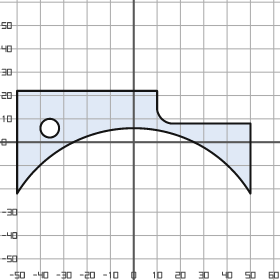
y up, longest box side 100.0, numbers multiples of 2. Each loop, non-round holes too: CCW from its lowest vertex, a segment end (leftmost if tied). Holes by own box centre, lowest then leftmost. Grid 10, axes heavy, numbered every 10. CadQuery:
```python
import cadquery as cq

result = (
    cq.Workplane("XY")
    .moveTo(-50.0, -22.0)
    .threePointArc((0.0, 6.0), (50.0, -22.0))
    .lineTo(50.0, 8.0)
    .lineTo(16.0, 8.0)
    .threePointArc((12.0, 10.0), (10.0, 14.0))
    .lineTo(10.0, 22.0)
    .lineTo(-50.0, 22.0)
    .close()
    .moveTo(-36.0, 6.0)
    .circle(4.0)
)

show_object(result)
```